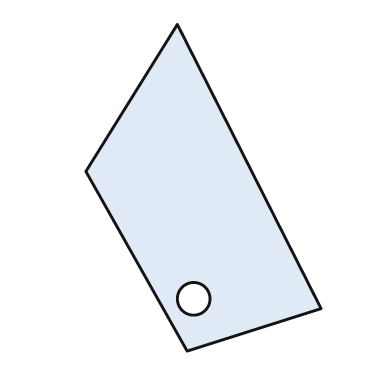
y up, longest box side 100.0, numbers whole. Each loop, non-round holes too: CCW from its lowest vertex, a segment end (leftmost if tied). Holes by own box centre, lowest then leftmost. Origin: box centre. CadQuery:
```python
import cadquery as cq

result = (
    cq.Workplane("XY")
    .moveTo(-5.0, -50.0)
    .lineTo(36.0, -37.0)
    .lineTo(-8.0, 50.0)
    .lineTo(-36.0, 5.0)
    .close()
    .moveTo(-3.0, -34.0)
    .circle(5.0)
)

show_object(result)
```